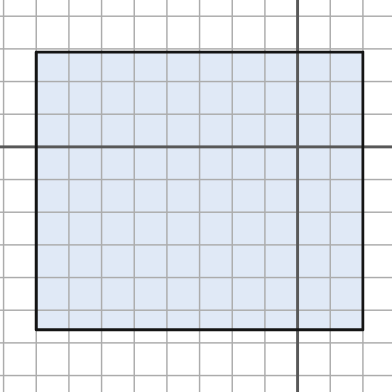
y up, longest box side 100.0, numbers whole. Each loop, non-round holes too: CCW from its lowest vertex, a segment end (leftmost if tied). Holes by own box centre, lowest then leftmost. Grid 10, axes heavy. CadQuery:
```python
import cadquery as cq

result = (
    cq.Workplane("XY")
    .moveTo(-80.0, -56.0)
    .lineTo(20.0, -56.0)
    .lineTo(20.0, 29.0)
    .lineTo(-80.0, 29.0)
    .close()
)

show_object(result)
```